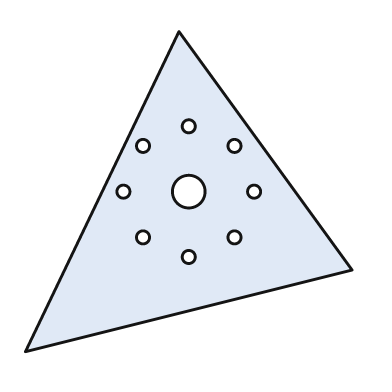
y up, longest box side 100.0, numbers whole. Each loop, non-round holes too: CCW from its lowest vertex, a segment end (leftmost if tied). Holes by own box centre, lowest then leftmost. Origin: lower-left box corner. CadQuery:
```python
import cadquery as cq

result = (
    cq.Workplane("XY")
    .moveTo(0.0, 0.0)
    .lineTo(100.0, 25.0)
    .lineTo(47.0, 98.0)
    .close()
    .moveTo(50.0, 29.0)
    .circle(2.0)
    .moveTo(36.0, 35.0)
    .circle(2.0)
    .moveTo(64.0, 35.0)
    .circle(2.0)
    .moveTo(30.0, 49.0)
    .circle(2.0)
    .moveTo(50.0, 49.0)
    .circle(5.0)
    .moveTo(70.0, 49.0)
    .circle(2.0)
    .moveTo(36.0, 63.0)
    .circle(2.0)
    .moveTo(64.0, 63.0)
    .circle(2.0)
    .moveTo(50.0, 69.0)
    .circle(2.0)
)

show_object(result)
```